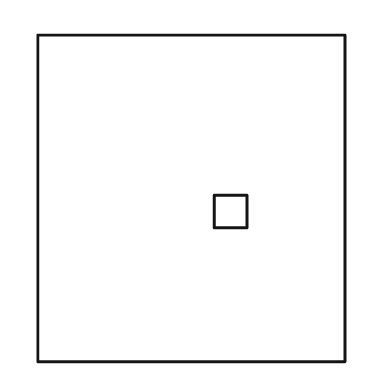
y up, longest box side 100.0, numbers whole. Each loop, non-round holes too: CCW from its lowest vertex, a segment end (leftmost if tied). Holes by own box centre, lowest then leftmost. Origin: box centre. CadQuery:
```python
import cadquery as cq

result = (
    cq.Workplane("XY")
    .moveTo(-47.0, -50.0)
    .lineTo(47.0, -50.0)
    .lineTo(47.0, 50.0)
    .lineTo(-47.0, 50.0)
    .close()
    .moveTo(7.0, -9.0)
    .lineTo(17.0, -9.0)
    .lineTo(17.0, 1.0)
    .lineTo(7.0, 1.0)
    .close()
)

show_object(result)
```